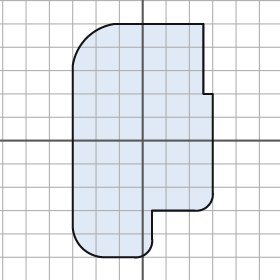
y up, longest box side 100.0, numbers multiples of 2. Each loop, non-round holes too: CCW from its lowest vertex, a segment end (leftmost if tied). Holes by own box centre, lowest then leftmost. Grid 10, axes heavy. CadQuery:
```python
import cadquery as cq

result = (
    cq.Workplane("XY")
    .moveTo(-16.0, -50.0)
    .lineTo(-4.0, -50.0)
    .threePointArc((2.0, -48.0), (4.0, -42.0))
    .lineTo(4.0, -30.0)
    .lineTo(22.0, -30.0)
    .threePointArc((28.0, -28.0), (30.0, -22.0))
    .lineTo(30.0, 20.0)
    .lineTo(26.0, 20.0)
    .lineTo(26.0, 50.0)
    .lineTo(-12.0, 50.0)
    .threePointArc((-24.0, 44.0), (-30.0, 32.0))
    .lineTo(-30.0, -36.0)
    .threePointArc((-26.0, -46.0), (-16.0, -50.0))
    .close()
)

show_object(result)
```